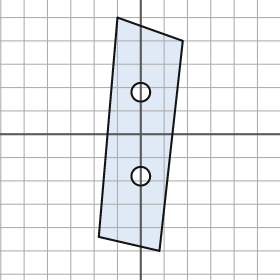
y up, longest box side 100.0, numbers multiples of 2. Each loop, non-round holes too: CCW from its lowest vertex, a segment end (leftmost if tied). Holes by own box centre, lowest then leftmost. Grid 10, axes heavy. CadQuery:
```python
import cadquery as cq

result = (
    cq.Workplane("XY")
    .moveTo(8.0, -50.0)
    .lineTo(18.0, 40.0)
    .lineTo(-10.0, 50.0)
    .lineTo(-18.0, -44.0)
    .close()
    .moveTo(0.0, -18.0)
    .circle(4.0)
    .moveTo(0.0, 18.0)
    .circle(4.0)
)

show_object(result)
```